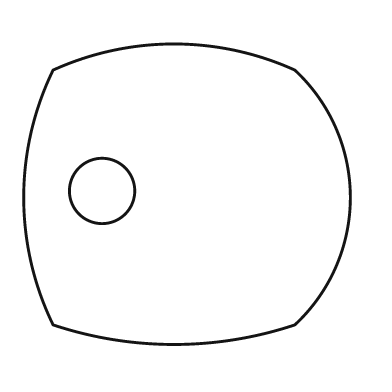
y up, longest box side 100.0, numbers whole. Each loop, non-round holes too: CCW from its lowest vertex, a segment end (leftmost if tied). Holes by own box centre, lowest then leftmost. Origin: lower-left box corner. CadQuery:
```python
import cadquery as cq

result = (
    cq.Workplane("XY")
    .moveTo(9.0, 6.0)
    .threePointArc((46.0, 0.0), (83.0, 6.0))
    .threePointArc((100.0, 45.0), (83.0, 84.0))
    .threePointArc((46.0, 92.0), (9.0, 84.0))
    .threePointArc((0.0, 45.0), (9.0, 6.0))
    .close()
    .moveTo(24.0, 47.0)
    .circle(10.0)
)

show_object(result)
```